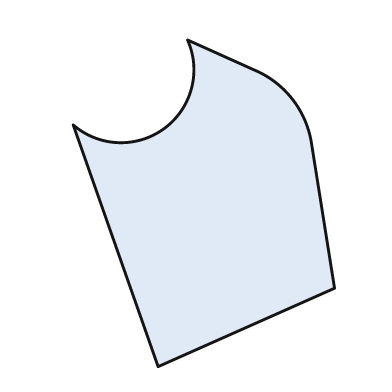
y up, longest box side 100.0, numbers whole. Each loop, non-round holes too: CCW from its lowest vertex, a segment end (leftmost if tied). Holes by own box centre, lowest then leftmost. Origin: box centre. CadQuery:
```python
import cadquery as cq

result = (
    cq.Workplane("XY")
    .moveTo(-14.0, -50.0)
    .lineTo(40.0, -26.0)
    .lineTo(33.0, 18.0)
    .threePointArc((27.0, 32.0), (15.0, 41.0))
    .lineTo(-5.0, 50.0)
    .threePointArc((-12.0, 23.0), (-40.0, 24.0))
    .close()
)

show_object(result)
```